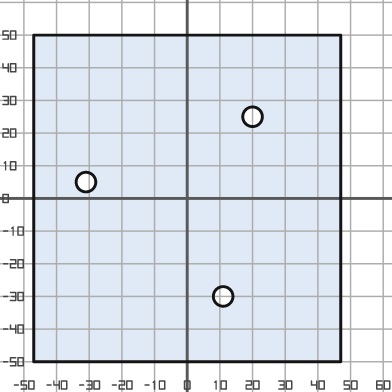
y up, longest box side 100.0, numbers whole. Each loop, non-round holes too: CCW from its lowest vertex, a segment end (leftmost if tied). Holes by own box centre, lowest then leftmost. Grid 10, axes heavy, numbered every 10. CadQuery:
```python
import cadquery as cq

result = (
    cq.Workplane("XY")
    .moveTo(-47.0, -50.0)
    .lineTo(47.0, -50.0)
    .lineTo(47.0, 50.0)
    .lineTo(-47.0, 50.0)
    .close()
    .moveTo(11.0, -30.0)
    .circle(3.0)
    .moveTo(-31.0, 5.0)
    .circle(3.0)
    .moveTo(20.0, 25.0)
    .circle(3.0)
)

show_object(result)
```